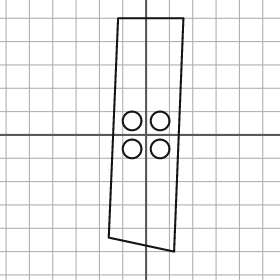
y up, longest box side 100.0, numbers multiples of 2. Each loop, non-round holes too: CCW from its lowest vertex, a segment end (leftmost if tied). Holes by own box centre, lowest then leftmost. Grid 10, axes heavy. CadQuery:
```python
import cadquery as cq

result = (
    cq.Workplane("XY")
    .moveTo(12.0, -50.0)
    .lineTo(16.0, 50.0)
    .lineTo(-12.0, 50.0)
    .lineTo(-16.0, -44.0)
    .close()
    .moveTo(-6.0, -6.0)
    .circle(4.0)
    .moveTo(6.0, -6.0)
    .circle(4.0)
    .moveTo(-6.0, 6.0)
    .circle(4.0)
    .moveTo(6.0, 6.0)
    .circle(4.0)
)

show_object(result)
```